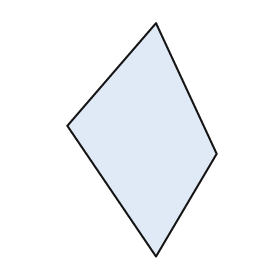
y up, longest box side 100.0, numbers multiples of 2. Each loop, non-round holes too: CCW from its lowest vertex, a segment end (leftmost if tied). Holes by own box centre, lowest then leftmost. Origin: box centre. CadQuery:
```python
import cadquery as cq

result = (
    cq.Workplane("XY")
    .moveTo(6.0, -50.0)
    .lineTo(32.0, -6.0)
    .lineTo(6.0, 50.0)
    .lineTo(-32.0, 6.0)
    .close()
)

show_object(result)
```